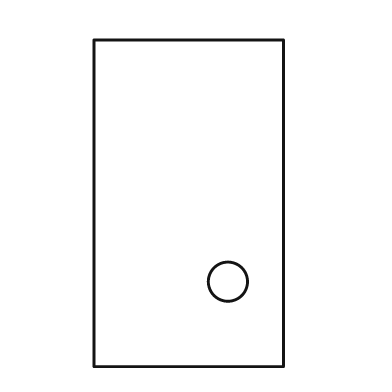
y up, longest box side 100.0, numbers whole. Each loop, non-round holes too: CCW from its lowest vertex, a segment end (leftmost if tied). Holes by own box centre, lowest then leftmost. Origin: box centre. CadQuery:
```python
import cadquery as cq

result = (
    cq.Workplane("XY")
    .moveTo(-29.0, -50.0)
    .lineTo(29.0, -50.0)
    .lineTo(29.0, 50.0)
    .lineTo(-29.0, 50.0)
    .close()
    .moveTo(12.0, -24.0)
    .circle(6.0)
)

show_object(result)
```